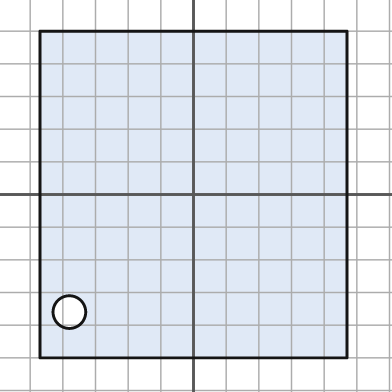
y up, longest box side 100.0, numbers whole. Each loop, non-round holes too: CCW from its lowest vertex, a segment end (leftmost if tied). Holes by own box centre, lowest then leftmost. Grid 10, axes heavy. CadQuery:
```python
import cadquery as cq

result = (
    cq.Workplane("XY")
    .moveTo(-47.0, -50.0)
    .lineTo(47.0, -50.0)
    .lineTo(47.0, 50.0)
    .lineTo(-47.0, 50.0)
    .close()
    .moveTo(-38.0, -36.0)
    .circle(5.0)
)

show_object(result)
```